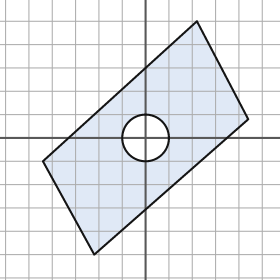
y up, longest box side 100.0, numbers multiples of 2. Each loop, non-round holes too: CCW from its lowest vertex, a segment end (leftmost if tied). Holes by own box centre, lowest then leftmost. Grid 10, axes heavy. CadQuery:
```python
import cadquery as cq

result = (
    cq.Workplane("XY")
    .moveTo(-22.0, -50.0)
    .lineTo(44.0, 8.0)
    .lineTo(22.0, 50.0)
    .lineTo(-44.0, -10.0)
    .close()
    .moveTo(0.0, 0.0)
    .circle(10.0)
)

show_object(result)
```